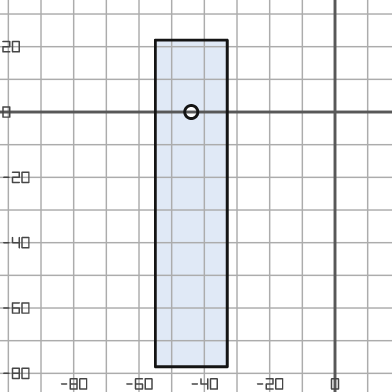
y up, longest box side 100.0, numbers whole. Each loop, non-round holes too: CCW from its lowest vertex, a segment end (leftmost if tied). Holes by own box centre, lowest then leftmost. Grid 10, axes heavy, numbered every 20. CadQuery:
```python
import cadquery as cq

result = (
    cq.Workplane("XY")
    .moveTo(-55.0, -78.0)
    .lineTo(-33.0, -78.0)
    .lineTo(-33.0, 22.0)
    .lineTo(-55.0, 22.0)
    .close()
    .moveTo(-44.0, 0.0)
    .circle(2.0)
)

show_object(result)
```